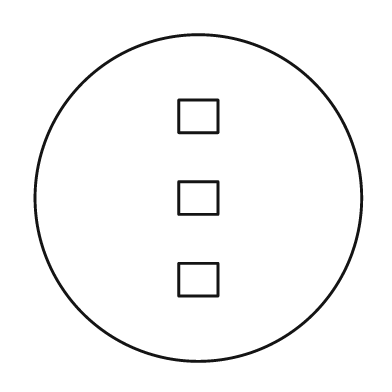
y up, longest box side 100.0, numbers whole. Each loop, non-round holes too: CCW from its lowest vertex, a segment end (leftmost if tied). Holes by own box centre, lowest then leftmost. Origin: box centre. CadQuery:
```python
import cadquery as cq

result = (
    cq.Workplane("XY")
    .moveTo(0.0, 0.0)
    .circle(50.0)
    .moveTo(-6.0, -30.0)
    .lineTo(6.0, -30.0)
    .lineTo(6.0, -20.0)
    .lineTo(-6.0, -20.0)
    .close()
    .moveTo(-6.0, -5.0)
    .lineTo(6.0, -5.0)
    .lineTo(6.0, 5.0)
    .lineTo(-6.0, 5.0)
    .close()
    .moveTo(-6.0, 20.0)
    .lineTo(6.0, 20.0)
    .lineTo(6.0, 30.0)
    .lineTo(-6.0, 30.0)
    .close()
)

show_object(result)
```